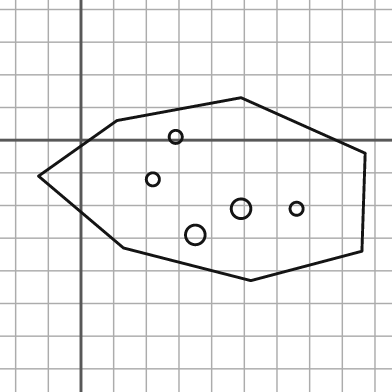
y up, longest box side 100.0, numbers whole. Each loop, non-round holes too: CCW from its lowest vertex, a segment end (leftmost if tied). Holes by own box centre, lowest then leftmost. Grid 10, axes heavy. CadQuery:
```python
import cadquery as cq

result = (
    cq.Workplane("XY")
    .moveTo(52.0, -43.0)
    .lineTo(86.0, -34.0)
    .lineTo(87.0, -4.0)
    .lineTo(49.0, 13.0)
    .lineTo(11.0, 6.0)
    .lineTo(-13.0, -11.0)
    .lineTo(13.0, -33.0)
    .close()
    .moveTo(35.0, -29.0)
    .circle(3.0)
    .moveTo(49.0, -21.0)
    .circle(3.0)
    .moveTo(66.0, -21.0)
    .circle(2.0)
    .moveTo(22.0, -12.0)
    .circle(2.0)
    .moveTo(29.0, 1.0)
    .circle(2.0)
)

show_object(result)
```